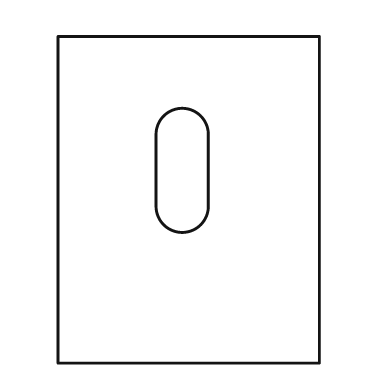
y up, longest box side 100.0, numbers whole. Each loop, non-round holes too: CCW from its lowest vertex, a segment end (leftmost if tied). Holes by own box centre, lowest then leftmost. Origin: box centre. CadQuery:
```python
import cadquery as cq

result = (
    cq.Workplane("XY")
    .moveTo(-40.0, -50.0)
    .lineTo(40.0, -50.0)
    .lineTo(40.0, 50.0)
    .lineTo(-40.0, 50.0)
    .close()
    .moveTo(-10.0, -2.0)
    .threePointArc((-2.0, -10.0), (6.0, -2.0))
    .lineTo(6.0, 20.0)
    .threePointArc((-2.0, 28.0), (-10.0, 20.0))
    .close()
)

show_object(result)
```